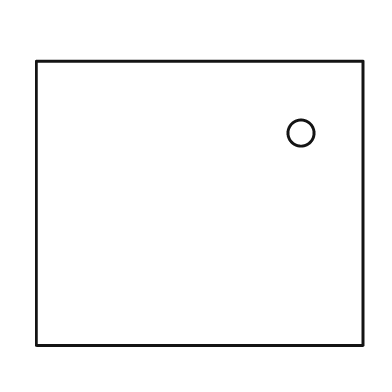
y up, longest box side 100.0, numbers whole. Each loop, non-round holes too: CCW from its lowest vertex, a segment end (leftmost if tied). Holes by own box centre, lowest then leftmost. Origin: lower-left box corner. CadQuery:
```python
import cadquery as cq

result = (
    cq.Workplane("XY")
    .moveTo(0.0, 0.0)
    .lineTo(100.0, 0.0)
    .lineTo(100.0, 87.0)
    .lineTo(0.0, 87.0)
    .close()
    .moveTo(81.0, 65.0)
    .circle(4.0)
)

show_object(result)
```